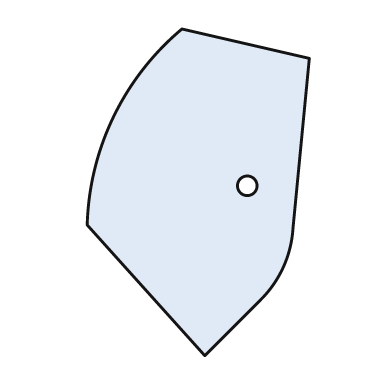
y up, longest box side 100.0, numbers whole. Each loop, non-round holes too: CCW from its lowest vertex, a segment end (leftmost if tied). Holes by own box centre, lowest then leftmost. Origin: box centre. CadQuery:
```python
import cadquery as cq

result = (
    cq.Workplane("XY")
    .moveTo(2.0, -50.0)
    .lineTo(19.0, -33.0)
    .threePointArc((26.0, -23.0), (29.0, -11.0))
    .lineTo(34.0, 41.0)
    .lineTo(-5.0, 50.0)
    .threePointArc((-26.0, 23.0), (-34.0, -10.0))
    .close()
    .moveTo(15.0, 2.0)
    .circle(3.0)
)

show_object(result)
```